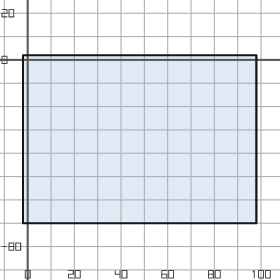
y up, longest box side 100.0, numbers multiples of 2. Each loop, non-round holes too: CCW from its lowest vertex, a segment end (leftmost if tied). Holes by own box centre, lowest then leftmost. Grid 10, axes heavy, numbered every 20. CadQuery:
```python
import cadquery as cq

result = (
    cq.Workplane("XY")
    .moveTo(-2.0, -70.0)
    .lineTo(98.0, -70.0)
    .lineTo(98.0, 2.0)
    .lineTo(-2.0, 2.0)
    .close()
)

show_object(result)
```